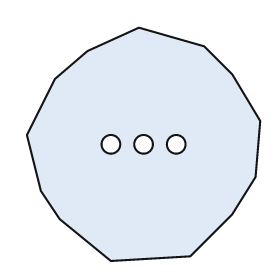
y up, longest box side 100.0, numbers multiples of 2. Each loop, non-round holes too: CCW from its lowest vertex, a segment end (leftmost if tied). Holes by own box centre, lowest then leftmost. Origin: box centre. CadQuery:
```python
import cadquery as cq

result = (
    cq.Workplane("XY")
    .moveTo(-14.0, -50.0)
    .lineTo(20.0, -48.0)
    .lineTo(38.0, -30.0)
    .lineTo(48.0, -14.0)
    .lineTo(50.0, 10.0)
    .lineTo(38.0, 30.0)
    .lineTo(26.0, 42.0)
    .lineTo(-2.0, 50.0)
    .lineTo(-24.0, 40.0)
    .lineTo(-38.0, 28.0)
    .lineTo(-50.0, 4.0)
    .lineTo(-44.0, -20.0)
    .lineTo(-36.0, -32.0)
    .close()
    .moveTo(-14.0, 0.0)
    .circle(4.0)
    .moveTo(0.0, 0.0)
    .circle(4.0)
    .moveTo(14.0, 0.0)
    .circle(4.0)
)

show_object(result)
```